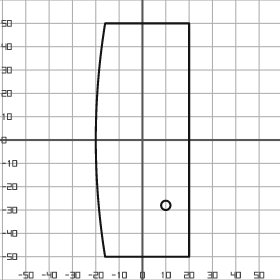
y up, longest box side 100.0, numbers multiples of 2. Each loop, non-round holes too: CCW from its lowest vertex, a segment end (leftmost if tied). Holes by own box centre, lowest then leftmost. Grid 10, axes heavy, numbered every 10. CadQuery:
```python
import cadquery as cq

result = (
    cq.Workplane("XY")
    .moveTo(-16.0, -50.0)
    .lineTo(20.0, -50.0)
    .lineTo(20.0, 50.0)
    .lineTo(-16.0, 50.0)
    .threePointArc((-20.0, 0.0), (-16.0, -50.0))
    .close()
    .moveTo(10.0, -28.0)
    .circle(2.0)
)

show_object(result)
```